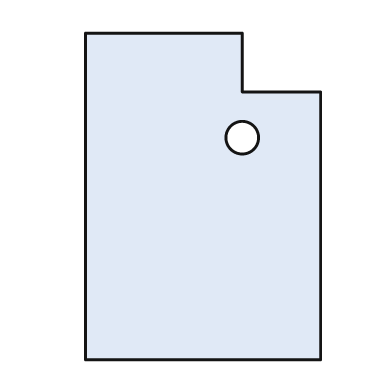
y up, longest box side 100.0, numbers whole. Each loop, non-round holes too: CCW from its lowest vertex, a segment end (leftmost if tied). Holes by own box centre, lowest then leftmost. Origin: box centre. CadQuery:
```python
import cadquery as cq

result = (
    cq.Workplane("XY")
    .moveTo(-36.0, -50.0)
    .lineTo(36.0, -50.0)
    .lineTo(36.0, 32.0)
    .lineTo(12.0, 32.0)
    .lineTo(12.0, 50.0)
    .lineTo(-36.0, 50.0)
    .close()
    .moveTo(12.0, 18.0)
    .circle(5.0)
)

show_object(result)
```